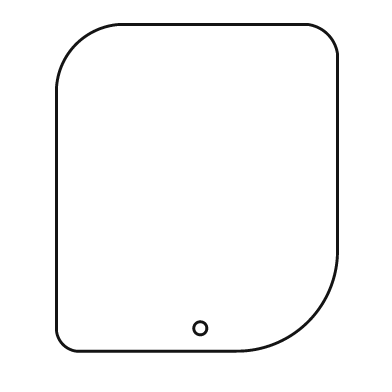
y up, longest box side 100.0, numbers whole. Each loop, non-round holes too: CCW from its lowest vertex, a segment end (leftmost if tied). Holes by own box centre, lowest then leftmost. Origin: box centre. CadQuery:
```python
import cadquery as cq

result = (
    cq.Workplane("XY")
    .moveTo(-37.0, -50.0)
    .lineTo(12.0, -50.0)
    .threePointArc((34.0, -41.0), (43.0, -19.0))
    .lineTo(43.0, 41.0)
    .threePointArc((40.0, 47.0), (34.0, 50.0))
    .lineTo(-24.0, 50.0)
    .threePointArc((-37.0, 44.0), (-43.0, 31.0))
    .lineTo(-43.0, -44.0)
    .threePointArc((-41.0, -48.0), (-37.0, -50.0))
    .close()
    .moveTo(1.0, -43.0)
    .circle(2.0)
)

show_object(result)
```